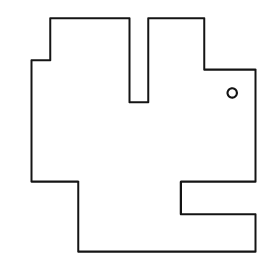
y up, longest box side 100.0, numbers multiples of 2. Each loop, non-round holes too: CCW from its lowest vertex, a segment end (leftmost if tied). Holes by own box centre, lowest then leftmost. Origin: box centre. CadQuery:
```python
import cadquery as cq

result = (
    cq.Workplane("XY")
    .moveTo(-28.0, -50.0)
    .lineTo(48.0, -50.0)
    .lineTo(48.0, -34.0)
    .lineTo(16.0, -34.0)
    .lineTo(16.0, -20.0)
    .lineTo(48.0, -20.0)
    .lineTo(48.0, 28.0)
    .lineTo(26.0, 28.0)
    .lineTo(26.0, 50.0)
    .lineTo(2.0, 50.0)
    .lineTo(2.0, 14.0)
    .lineTo(-6.0, 14.0)
    .lineTo(-6.0, 50.0)
    .lineTo(-40.0, 50.0)
    .lineTo(-40.0, 32.0)
    .lineTo(-48.0, 32.0)
    .lineTo(-48.0, -20.0)
    .lineTo(-28.0, -20.0)
    .close()
    .moveTo(38.0, 18.0)
    .circle(2.0)
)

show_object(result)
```